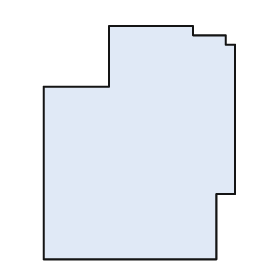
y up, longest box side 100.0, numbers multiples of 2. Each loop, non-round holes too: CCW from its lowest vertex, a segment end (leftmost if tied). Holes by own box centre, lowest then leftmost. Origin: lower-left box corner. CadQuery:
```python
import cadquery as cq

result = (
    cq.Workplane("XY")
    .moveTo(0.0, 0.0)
    .lineTo(74.0, 0.0)
    .lineTo(74.0, 28.0)
    .lineTo(82.0, 28.0)
    .lineTo(82.0, 92.0)
    .lineTo(78.0, 92.0)
    .lineTo(78.0, 96.0)
    .lineTo(64.0, 96.0)
    .lineTo(64.0, 100.0)
    .lineTo(28.0, 100.0)
    .lineTo(28.0, 74.0)
    .lineTo(0.0, 74.0)
    .close()
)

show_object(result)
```